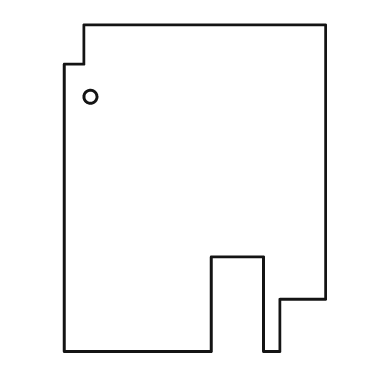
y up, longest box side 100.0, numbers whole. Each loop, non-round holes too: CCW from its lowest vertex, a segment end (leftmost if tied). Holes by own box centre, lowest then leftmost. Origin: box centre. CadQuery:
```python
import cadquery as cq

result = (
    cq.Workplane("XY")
    .moveTo(-40.0, -50.0)
    .lineTo(5.0, -50.0)
    .lineTo(5.0, -21.0)
    .lineTo(21.0, -21.0)
    .lineTo(21.0, -50.0)
    .lineTo(26.0, -50.0)
    .lineTo(26.0, -34.0)
    .lineTo(40.0, -34.0)
    .lineTo(40.0, 50.0)
    .lineTo(-34.0, 50.0)
    .lineTo(-34.0, 38.0)
    .lineTo(-40.0, 38.0)
    .close()
    .moveTo(-32.0, 28.0)
    .circle(2.0)
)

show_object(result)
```